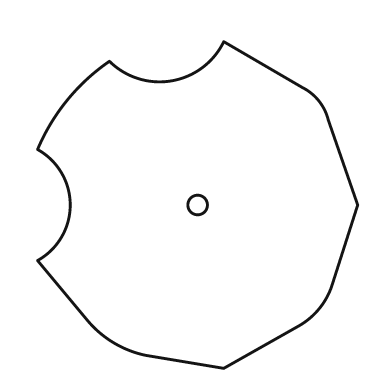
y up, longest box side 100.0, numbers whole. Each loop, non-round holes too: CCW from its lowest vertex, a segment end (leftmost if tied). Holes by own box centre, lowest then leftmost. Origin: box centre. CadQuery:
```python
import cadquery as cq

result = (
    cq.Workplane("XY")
    .moveTo(8.0, -50.0)
    .lineTo(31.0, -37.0)
    .threePointArc((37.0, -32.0), (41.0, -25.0))
    .lineTo(49.0, 0.0)
    .lineTo(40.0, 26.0)
    .threePointArc((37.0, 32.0), (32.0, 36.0))
    .lineTo(8.0, 50.0)
    .threePointArc((-8.0, 38.0), (-27.0, 44.0))
    .threePointArc((-40.0, 32.0), (-49.0, 17.0))
    .threePointArc((-39.0, 0.0), (-49.0, -17.0))
    .lineTo(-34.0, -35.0)
    .threePointArc((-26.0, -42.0), (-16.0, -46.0))
    .close()
    .moveTo(0.0, 0.0)
    .circle(3.0)
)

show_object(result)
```